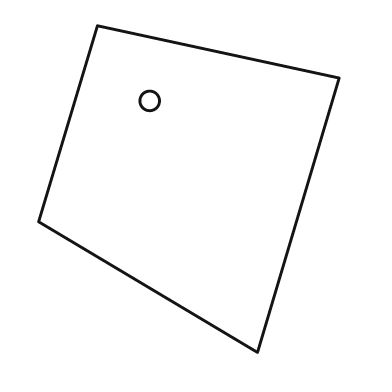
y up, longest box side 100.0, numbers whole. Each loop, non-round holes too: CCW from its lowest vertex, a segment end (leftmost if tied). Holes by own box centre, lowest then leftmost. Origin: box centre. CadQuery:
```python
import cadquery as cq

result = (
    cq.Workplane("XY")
    .moveTo(21.0, -50.0)
    .lineTo(46.0, 34.0)
    .lineTo(-28.0, 50.0)
    .lineTo(-46.0, -10.0)
    .close()
    .moveTo(-12.0, 27.0)
    .circle(3.0)
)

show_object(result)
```